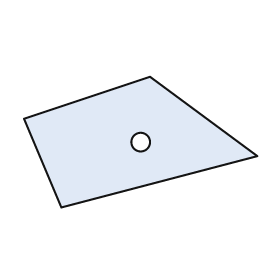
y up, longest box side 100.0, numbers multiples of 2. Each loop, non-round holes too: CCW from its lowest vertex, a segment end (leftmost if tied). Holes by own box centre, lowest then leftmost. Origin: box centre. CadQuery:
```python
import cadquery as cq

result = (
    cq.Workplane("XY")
    .moveTo(-34.0, -28.0)
    .lineTo(50.0, -6.0)
    .lineTo(4.0, 28.0)
    .lineTo(-50.0, 10.0)
    .close()
    .moveTo(0.0, 0.0)
    .circle(4.0)
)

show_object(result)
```